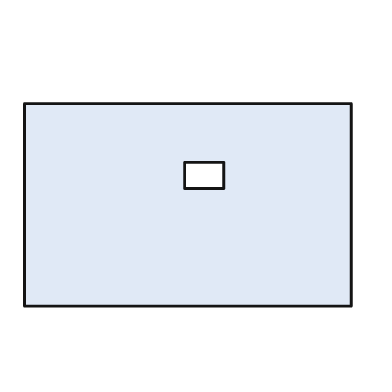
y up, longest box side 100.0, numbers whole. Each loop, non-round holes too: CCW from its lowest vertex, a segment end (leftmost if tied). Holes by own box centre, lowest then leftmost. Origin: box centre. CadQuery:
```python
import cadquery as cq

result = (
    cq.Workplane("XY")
    .moveTo(-50.0, -31.0)
    .lineTo(50.0, -31.0)
    .lineTo(50.0, 31.0)
    .lineTo(-50.0, 31.0)
    .close()
    .moveTo(-1.0, 5.0)
    .lineTo(11.0, 5.0)
    .lineTo(11.0, 13.0)
    .lineTo(-1.0, 13.0)
    .close()
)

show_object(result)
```